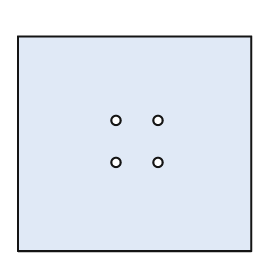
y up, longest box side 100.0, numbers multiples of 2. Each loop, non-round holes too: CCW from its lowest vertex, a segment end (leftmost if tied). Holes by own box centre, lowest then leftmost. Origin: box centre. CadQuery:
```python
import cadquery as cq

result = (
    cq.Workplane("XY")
    .moveTo(-50.0, -46.0)
    .lineTo(50.0, -46.0)
    .lineTo(50.0, 46.0)
    .lineTo(-50.0, 46.0)
    .close()
    .moveTo(-8.0, -8.0)
    .circle(2.0)
    .moveTo(10.0, -8.0)
    .circle(2.0)
    .moveTo(-8.0, 10.0)
    .circle(2.0)
    .moveTo(10.0, 10.0)
    .circle(2.0)
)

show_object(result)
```